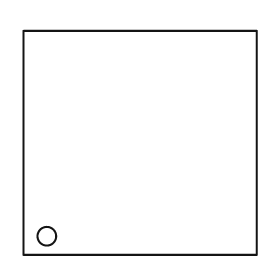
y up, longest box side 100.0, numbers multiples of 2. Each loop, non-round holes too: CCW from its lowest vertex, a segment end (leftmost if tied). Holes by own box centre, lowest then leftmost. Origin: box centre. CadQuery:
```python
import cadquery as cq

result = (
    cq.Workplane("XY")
    .moveTo(-50.0, -48.0)
    .lineTo(50.0, -48.0)
    .lineTo(50.0, 48.0)
    .lineTo(-50.0, 48.0)
    .close()
    .moveTo(-40.0, -40.0)
    .circle(4.0)
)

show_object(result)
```